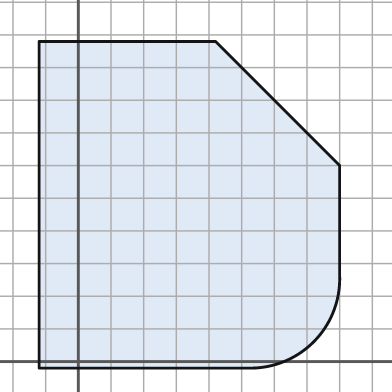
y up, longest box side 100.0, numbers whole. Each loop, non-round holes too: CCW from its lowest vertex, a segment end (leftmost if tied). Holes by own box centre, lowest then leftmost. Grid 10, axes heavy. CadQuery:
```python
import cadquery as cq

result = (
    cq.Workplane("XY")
    .moveTo(-12.0, -2.0)
    .lineTo(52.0, -2.0)
    .threePointArc((72.0, 6.0), (80.0, 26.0))
    .lineTo(80.0, 60.0)
    .lineTo(42.0, 98.0)
    .lineTo(-12.0, 98.0)
    .close()
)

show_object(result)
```